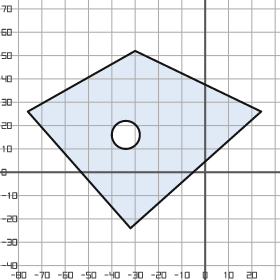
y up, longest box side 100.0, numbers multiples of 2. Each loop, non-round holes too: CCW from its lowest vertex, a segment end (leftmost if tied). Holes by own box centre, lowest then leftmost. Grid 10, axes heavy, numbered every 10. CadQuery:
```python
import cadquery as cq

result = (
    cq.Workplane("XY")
    .moveTo(-32.0, -24.0)
    .lineTo(24.0, 26.0)
    .lineTo(-30.0, 52.0)
    .lineTo(-76.0, 26.0)
    .close()
    .moveTo(-34.0, 16.0)
    .circle(6.0)
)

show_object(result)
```